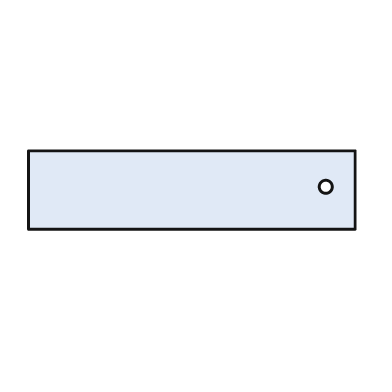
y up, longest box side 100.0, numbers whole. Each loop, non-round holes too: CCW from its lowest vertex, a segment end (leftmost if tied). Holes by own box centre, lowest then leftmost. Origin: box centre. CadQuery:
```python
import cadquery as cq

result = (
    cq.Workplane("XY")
    .moveTo(-50.0, -12.0)
    .lineTo(50.0, -12.0)
    .lineTo(50.0, 12.0)
    .lineTo(-50.0, 12.0)
    .close()
    .moveTo(41.0, 1.0)
    .circle(2.0)
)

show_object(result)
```